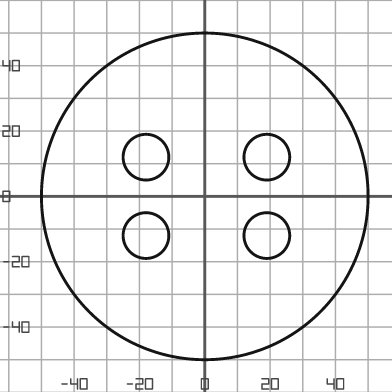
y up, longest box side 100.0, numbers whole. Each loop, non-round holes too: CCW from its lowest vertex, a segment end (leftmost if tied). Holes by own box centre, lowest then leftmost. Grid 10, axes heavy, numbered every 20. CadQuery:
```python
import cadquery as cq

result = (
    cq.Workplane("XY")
    .moveTo(0.0, 0.0)
    .circle(50.0)
    .moveTo(-18.0, -12.0)
    .circle(7.0)
    .moveTo(19.0, -12.0)
    .circle(7.0)
    .moveTo(-18.0, 12.0)
    .circle(7.0)
    .moveTo(19.0, 12.0)
    .circle(7.0)
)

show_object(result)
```